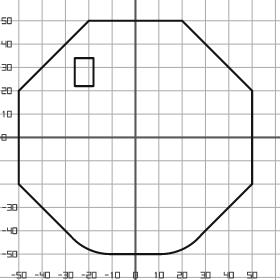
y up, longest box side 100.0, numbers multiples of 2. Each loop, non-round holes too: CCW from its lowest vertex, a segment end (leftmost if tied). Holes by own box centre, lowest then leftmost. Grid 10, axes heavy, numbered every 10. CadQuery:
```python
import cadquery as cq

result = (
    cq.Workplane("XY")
    .moveTo(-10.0, -50.0)
    .lineTo(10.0, -50.0)
    .threePointArc((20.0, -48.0), (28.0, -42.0))
    .lineTo(50.0, -20.0)
    .lineTo(50.0, 20.0)
    .lineTo(20.0, 50.0)
    .lineTo(-20.0, 50.0)
    .lineTo(-50.0, 20.0)
    .lineTo(-50.0, -20.0)
    .lineTo(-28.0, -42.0)
    .threePointArc((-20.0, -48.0), (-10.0, -50.0))
    .close()
    .moveTo(-26.0, 22.0)
    .lineTo(-18.0, 22.0)
    .lineTo(-18.0, 34.0)
    .lineTo(-26.0, 34.0)
    .close()
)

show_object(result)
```